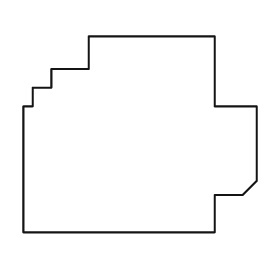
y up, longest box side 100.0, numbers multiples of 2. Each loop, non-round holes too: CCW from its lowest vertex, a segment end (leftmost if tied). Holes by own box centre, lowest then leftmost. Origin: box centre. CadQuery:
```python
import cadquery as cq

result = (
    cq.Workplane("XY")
    .moveTo(-50.0, -42.0)
    .lineTo(32.0, -42.0)
    .lineTo(32.0, -26.0)
    .lineTo(44.0, -26.0)
    .lineTo(50.0, -20.0)
    .lineTo(50.0, 12.0)
    .lineTo(32.0, 12.0)
    .lineTo(32.0, 42.0)
    .lineTo(-22.0, 42.0)
    .lineTo(-22.0, 28.0)
    .lineTo(-38.0, 28.0)
    .lineTo(-38.0, 20.0)
    .lineTo(-46.0, 20.0)
    .lineTo(-46.0, 12.0)
    .lineTo(-50.0, 12.0)
    .close()
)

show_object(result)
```